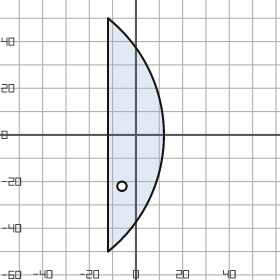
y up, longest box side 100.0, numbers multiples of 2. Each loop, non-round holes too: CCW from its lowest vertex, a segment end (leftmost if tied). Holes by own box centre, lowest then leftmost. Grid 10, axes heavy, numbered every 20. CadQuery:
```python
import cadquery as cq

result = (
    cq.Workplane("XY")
    .moveTo(-12.0, -50.0)
    .threePointArc((12.0, 0.0), (-12.0, 50.0))
    .close()
    .moveTo(-6.0, -22.0)
    .circle(2.0)
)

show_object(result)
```